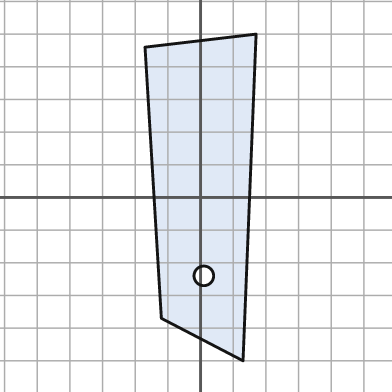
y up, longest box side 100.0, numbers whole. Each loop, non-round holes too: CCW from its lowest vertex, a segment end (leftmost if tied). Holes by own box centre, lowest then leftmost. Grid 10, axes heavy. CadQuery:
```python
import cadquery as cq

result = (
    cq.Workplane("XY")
    .moveTo(13.0, -50.0)
    .lineTo(17.0, 50.0)
    .lineTo(-17.0, 46.0)
    .lineTo(-12.0, -37.0)
    .close()
    .moveTo(1.0, -24.0)
    .circle(3.0)
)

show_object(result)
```